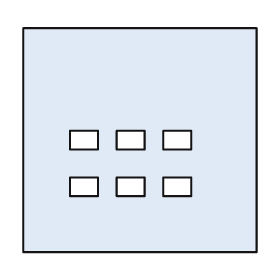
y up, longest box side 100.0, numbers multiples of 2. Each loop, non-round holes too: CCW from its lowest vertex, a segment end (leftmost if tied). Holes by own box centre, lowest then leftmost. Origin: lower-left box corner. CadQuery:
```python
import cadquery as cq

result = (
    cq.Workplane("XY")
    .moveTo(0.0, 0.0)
    .lineTo(100.0, 0.0)
    .lineTo(100.0, 96.0)
    .lineTo(0.0, 96.0)
    .close()
    .moveTo(20.0, 24.0)
    .lineTo(32.0, 24.0)
    .lineTo(32.0, 32.0)
    .lineTo(20.0, 32.0)
    .close()
    .moveTo(40.0, 24.0)
    .lineTo(52.0, 24.0)
    .lineTo(52.0, 32.0)
    .lineTo(40.0, 32.0)
    .close()
    .moveTo(60.0, 24.0)
    .lineTo(72.0, 24.0)
    .lineTo(72.0, 32.0)
    .lineTo(60.0, 32.0)
    .close()
    .moveTo(20.0, 44.0)
    .lineTo(32.0, 44.0)
    .lineTo(32.0, 52.0)
    .lineTo(20.0, 52.0)
    .close()
    .moveTo(40.0, 44.0)
    .lineTo(52.0, 44.0)
    .lineTo(52.0, 52.0)
    .lineTo(40.0, 52.0)
    .close()
    .moveTo(60.0, 44.0)
    .lineTo(72.0, 44.0)
    .lineTo(72.0, 52.0)
    .lineTo(60.0, 52.0)
    .close()
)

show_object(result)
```